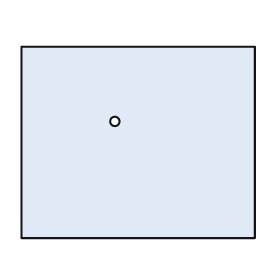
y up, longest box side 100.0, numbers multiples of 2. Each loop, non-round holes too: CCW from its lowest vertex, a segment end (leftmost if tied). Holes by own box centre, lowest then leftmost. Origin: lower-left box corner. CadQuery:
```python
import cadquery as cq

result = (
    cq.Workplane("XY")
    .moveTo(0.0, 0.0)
    .lineTo(100.0, 0.0)
    .lineTo(100.0, 82.0)
    .lineTo(0.0, 82.0)
    .close()
    .moveTo(40.0, 50.0)
    .circle(2.0)
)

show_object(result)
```